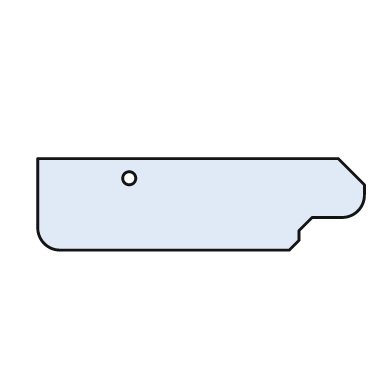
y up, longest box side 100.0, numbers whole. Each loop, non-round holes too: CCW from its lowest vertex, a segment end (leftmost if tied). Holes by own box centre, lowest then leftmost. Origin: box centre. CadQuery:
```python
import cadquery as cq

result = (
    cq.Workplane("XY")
    .moveTo(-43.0, -14.0)
    .lineTo(27.0, -14.0)
    .lineTo(30.0, -11.0)
    .lineTo(30.0, -8.0)
    .lineTo(34.0, -4.0)
    .lineTo(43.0, -4.0)
    .threePointArc((48.0, -2.0), (50.0, 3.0))
    .lineTo(50.0, 6.0)
    .lineTo(42.0, 14.0)
    .lineTo(-50.0, 14.0)
    .lineTo(-50.0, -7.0)
    .threePointArc((-48.0, -12.0), (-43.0, -14.0))
    .close()
    .moveTo(-22.0, 8.0)
    .circle(2.0)
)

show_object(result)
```